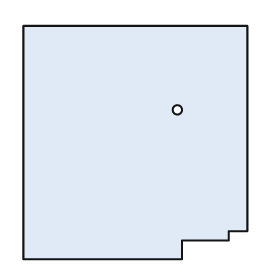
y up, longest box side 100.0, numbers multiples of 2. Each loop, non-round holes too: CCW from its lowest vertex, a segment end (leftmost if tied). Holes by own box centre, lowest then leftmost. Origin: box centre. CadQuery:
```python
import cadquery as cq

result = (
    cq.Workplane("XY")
    .moveTo(-48.0, -50.0)
    .lineTo(20.0, -50.0)
    .lineTo(20.0, -42.0)
    .lineTo(40.0, -42.0)
    .lineTo(40.0, -38.0)
    .lineTo(48.0, -38.0)
    .lineTo(48.0, 50.0)
    .lineTo(-48.0, 50.0)
    .close()
    .moveTo(18.0, 14.0)
    .circle(2.0)
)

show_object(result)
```